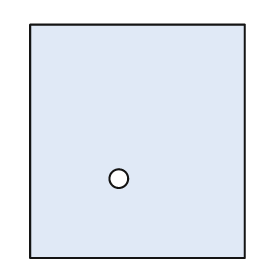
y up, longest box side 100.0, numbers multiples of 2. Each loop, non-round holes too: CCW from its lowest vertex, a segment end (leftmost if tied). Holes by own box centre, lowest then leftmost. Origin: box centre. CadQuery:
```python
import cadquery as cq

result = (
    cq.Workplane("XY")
    .moveTo(-46.0, -50.0)
    .lineTo(46.0, -50.0)
    .lineTo(46.0, 50.0)
    .lineTo(-46.0, 50.0)
    .close()
    .moveTo(-8.0, -16.0)
    .circle(4.0)
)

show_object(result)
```